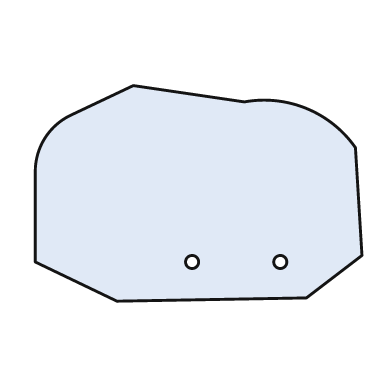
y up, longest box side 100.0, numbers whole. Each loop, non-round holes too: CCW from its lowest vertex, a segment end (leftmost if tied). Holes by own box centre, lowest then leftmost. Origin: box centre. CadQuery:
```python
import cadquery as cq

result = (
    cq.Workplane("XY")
    .moveTo(-25.0, -33.0)
    .lineTo(33.0, -32.0)
    .lineTo(50.0, -19.0)
    .lineTo(48.0, 14.0)
    .threePointArc((33.0, 26.0), (14.0, 28.0))
    .lineTo(-20.0, 33.0)
    .lineTo(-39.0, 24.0)
    .threePointArc((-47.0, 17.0), (-50.0, 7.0))
    .lineTo(-50.0, -21.0)
    .close()
    .moveTo(-2.0, -21.0)
    .circle(2.0)
    .moveTo(25.0, -21.0)
    .circle(2.0)
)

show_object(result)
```